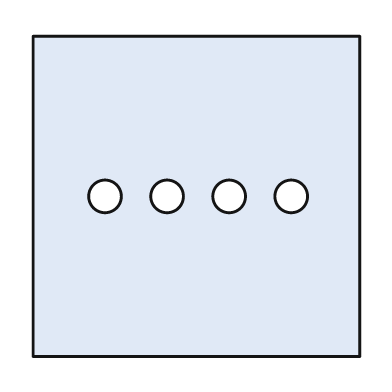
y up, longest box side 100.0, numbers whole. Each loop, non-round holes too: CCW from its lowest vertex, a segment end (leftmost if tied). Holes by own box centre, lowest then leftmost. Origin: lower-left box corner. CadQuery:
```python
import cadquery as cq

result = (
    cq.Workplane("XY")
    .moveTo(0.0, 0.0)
    .lineTo(100.0, 0.0)
    .lineTo(100.0, 98.0)
    .lineTo(0.0, 98.0)
    .close()
    .moveTo(22.0, 49.0)
    .circle(5.0)
    .moveTo(41.0, 49.0)
    .circle(5.0)
    .moveTo(60.0, 49.0)
    .circle(5.0)
    .moveTo(79.0, 49.0)
    .circle(5.0)
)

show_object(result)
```